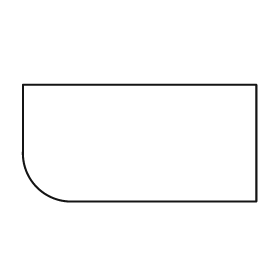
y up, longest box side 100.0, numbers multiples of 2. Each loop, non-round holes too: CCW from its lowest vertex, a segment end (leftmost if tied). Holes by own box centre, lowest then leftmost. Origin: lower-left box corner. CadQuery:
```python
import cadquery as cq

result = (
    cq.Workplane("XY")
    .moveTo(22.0, 0.0)
    .lineTo(100.0, 0.0)
    .lineTo(100.0, 50.0)
    .lineTo(0.0, 50.0)
    .lineTo(0.0, 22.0)
    .threePointArc((6.0, 6.0), (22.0, 0.0))
    .close()
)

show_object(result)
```